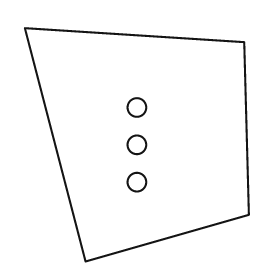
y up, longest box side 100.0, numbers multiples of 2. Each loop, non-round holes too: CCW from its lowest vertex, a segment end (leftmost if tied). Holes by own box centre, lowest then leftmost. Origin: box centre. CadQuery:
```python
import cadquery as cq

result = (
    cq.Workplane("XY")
    .moveTo(-22.0, -50.0)
    .lineTo(48.0, -30.0)
    .lineTo(46.0, 44.0)
    .lineTo(-48.0, 50.0)
    .close()
    .moveTo(0.0, -16.0)
    .circle(4.0)
    .moveTo(0.0, 0.0)
    .circle(4.0)
    .moveTo(0.0, 16.0)
    .circle(4.0)
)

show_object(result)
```